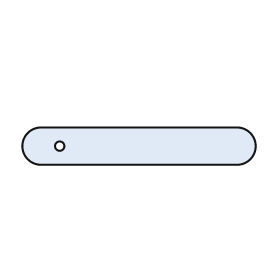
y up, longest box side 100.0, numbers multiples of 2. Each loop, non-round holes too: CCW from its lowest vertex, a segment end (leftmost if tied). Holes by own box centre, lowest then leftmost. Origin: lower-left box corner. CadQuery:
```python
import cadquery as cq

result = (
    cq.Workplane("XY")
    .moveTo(8.0, 0.0)
    .lineTo(92.0, 0.0)
    .threePointArc((100.0, 8.0), (92.0, 16.0))
    .lineTo(8.0, 16.0)
    .threePointArc((0.0, 8.0), (8.0, 0.0))
    .close()
    .moveTo(16.0, 8.0)
    .circle(2.0)
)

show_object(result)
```